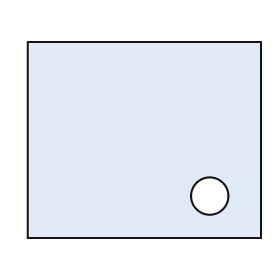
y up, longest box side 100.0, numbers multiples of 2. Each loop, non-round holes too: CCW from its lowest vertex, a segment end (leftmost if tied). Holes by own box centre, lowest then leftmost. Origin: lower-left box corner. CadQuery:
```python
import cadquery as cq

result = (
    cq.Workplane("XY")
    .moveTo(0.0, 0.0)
    .lineTo(100.0, 0.0)
    .lineTo(100.0, 84.0)
    .lineTo(0.0, 84.0)
    .close()
    .moveTo(78.0, 18.0)
    .circle(8.0)
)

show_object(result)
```